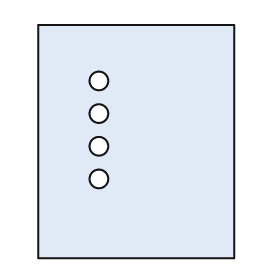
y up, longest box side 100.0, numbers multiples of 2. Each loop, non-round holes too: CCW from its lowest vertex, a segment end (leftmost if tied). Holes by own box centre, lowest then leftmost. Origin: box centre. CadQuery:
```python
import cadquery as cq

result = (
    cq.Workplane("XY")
    .moveTo(-42.0, -50.0)
    .lineTo(42.0, -50.0)
    .lineTo(42.0, 50.0)
    .lineTo(-42.0, 50.0)
    .close()
    .moveTo(-16.0, -16.0)
    .circle(4.0)
    .moveTo(-16.0, -2.0)
    .circle(4.0)
    .moveTo(-16.0, 12.0)
    .circle(4.0)
    .moveTo(-16.0, 26.0)
    .circle(4.0)
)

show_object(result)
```